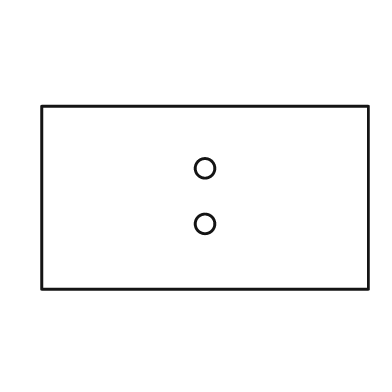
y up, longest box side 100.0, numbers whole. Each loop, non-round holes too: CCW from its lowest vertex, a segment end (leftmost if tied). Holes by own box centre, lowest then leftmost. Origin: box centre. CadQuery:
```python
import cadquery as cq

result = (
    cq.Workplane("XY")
    .moveTo(-50.0, -28.0)
    .lineTo(50.0, -28.0)
    .lineTo(50.0, 28.0)
    .lineTo(-50.0, 28.0)
    .close()
    .moveTo(0.0, -8.0)
    .circle(3.0)
    .moveTo(0.0, 9.0)
    .circle(3.0)
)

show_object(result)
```